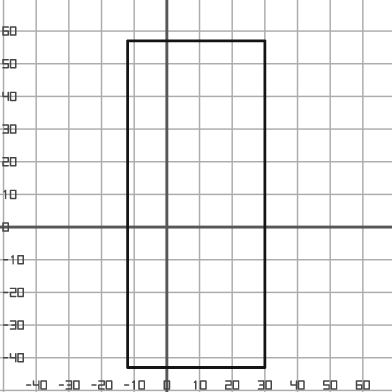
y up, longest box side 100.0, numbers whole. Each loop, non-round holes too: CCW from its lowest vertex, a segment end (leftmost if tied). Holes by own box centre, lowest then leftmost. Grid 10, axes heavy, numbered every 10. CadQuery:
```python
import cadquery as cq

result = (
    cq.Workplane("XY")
    .moveTo(-12.0, -43.0)
    .lineTo(30.0, -43.0)
    .lineTo(30.0, 57.0)
    .lineTo(-12.0, 57.0)
    .close()
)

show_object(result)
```